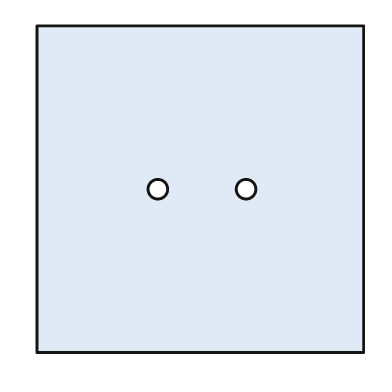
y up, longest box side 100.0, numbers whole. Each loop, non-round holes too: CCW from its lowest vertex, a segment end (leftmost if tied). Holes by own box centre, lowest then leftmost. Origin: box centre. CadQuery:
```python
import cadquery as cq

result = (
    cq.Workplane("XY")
    .moveTo(-50.0, -50.0)
    .lineTo(50.0, -50.0)
    .lineTo(50.0, 50.0)
    .lineTo(-50.0, 50.0)
    .close()
    .moveTo(-13.0, 0.0)
    .circle(3.0)
    .moveTo(14.0, 0.0)
    .circle(3.0)
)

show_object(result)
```